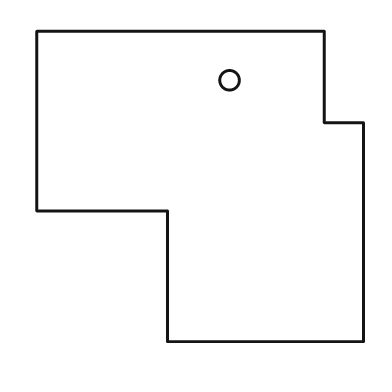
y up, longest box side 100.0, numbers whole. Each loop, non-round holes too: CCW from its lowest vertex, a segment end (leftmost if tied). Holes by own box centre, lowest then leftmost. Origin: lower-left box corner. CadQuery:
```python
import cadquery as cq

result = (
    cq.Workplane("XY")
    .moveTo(40.0, 0.0)
    .lineTo(100.0, 0.0)
    .lineTo(100.0, 67.0)
    .lineTo(88.0, 67.0)
    .lineTo(88.0, 95.0)
    .lineTo(0.0, 95.0)
    .lineTo(0.0, 40.0)
    .lineTo(40.0, 40.0)
    .close()
    .moveTo(59.0, 80.0)
    .circle(3.0)
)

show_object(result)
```